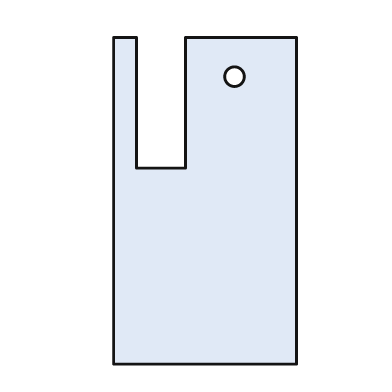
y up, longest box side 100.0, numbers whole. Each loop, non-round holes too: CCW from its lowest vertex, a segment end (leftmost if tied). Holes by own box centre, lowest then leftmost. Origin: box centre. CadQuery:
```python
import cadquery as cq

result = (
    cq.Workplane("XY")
    .moveTo(-28.0, -50.0)
    .lineTo(28.0, -50.0)
    .lineTo(28.0, 50.0)
    .lineTo(-6.0, 50.0)
    .lineTo(-6.0, 10.0)
    .lineTo(-21.0, 10.0)
    .lineTo(-21.0, 50.0)
    .lineTo(-28.0, 50.0)
    .close()
    .moveTo(9.0, 38.0)
    .circle(3.0)
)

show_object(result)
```